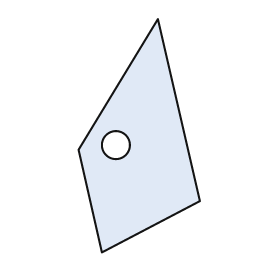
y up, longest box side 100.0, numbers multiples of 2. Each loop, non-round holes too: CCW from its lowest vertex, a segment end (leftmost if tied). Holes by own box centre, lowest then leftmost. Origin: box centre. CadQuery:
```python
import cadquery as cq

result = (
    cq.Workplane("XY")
    .moveTo(-16.0, -50.0)
    .lineTo(26.0, -28.0)
    .lineTo(8.0, 50.0)
    .lineTo(-26.0, -6.0)
    .close()
    .moveTo(-10.0, -4.0)
    .circle(6.0)
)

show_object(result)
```